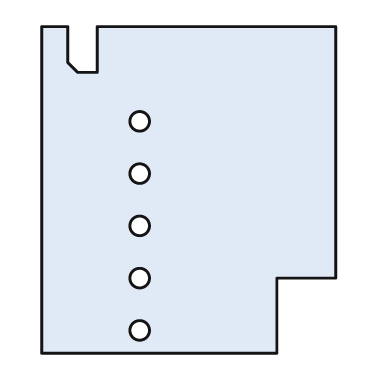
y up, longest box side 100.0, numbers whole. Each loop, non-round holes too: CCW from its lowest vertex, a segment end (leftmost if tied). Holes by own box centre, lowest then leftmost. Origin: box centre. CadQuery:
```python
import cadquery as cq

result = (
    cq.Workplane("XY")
    .moveTo(-45.0, -50.0)
    .lineTo(27.0, -50.0)
    .lineTo(27.0, -27.0)
    .lineTo(45.0, -27.0)
    .lineTo(45.0, 50.0)
    .lineTo(-28.0, 50.0)
    .lineTo(-28.0, 36.0)
    .lineTo(-34.0, 36.0)
    .lineTo(-37.0, 39.0)
    .lineTo(-37.0, 50.0)
    .lineTo(-45.0, 50.0)
    .close()
    .moveTo(-15.0, -43.0)
    .circle(3.0)
    .moveTo(-15.0, -27.0)
    .circle(3.0)
    .moveTo(-15.0, -11.0)
    .circle(3.0)
    .moveTo(-15.0, 5.0)
    .circle(3.0)
    .moveTo(-15.0, 21.0)
    .circle(3.0)
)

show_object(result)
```